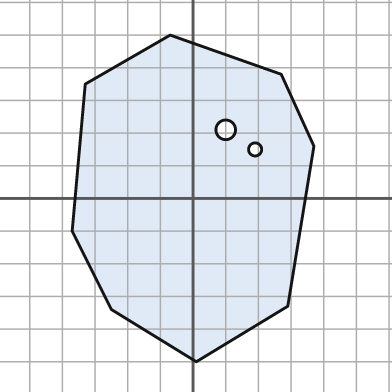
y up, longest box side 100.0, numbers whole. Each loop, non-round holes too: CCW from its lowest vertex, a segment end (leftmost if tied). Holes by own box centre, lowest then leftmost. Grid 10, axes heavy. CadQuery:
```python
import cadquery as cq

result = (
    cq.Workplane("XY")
    .moveTo(1.0, -50.0)
    .lineTo(29.0, -33.0)
    .lineTo(37.0, 16.0)
    .lineTo(27.0, 38.0)
    .lineTo(-7.0, 50.0)
    .lineTo(-33.0, 35.0)
    .lineTo(-37.0, -10.0)
    .lineTo(-25.0, -34.0)
    .close()
    .moveTo(19.0, 15.0)
    .circle(2.0)
    .moveTo(10.0, 21.0)
    .circle(3.0)
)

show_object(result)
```